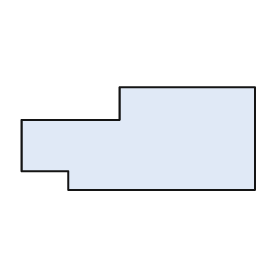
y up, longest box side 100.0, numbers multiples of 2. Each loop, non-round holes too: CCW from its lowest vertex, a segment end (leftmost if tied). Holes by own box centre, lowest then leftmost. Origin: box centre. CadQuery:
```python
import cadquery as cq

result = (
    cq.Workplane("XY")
    .moveTo(-30.0, -22.0)
    .lineTo(50.0, -22.0)
    .lineTo(50.0, 22.0)
    .lineTo(-8.0, 22.0)
    .lineTo(-8.0, 8.0)
    .lineTo(-50.0, 8.0)
    .lineTo(-50.0, -14.0)
    .lineTo(-30.0, -14.0)
    .close()
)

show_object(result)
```